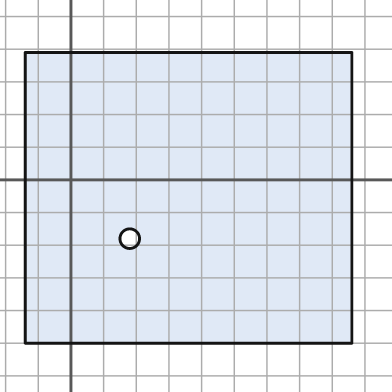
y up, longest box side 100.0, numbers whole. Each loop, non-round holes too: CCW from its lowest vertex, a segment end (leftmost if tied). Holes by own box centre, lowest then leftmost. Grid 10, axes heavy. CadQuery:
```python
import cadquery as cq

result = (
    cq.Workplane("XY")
    .moveTo(-14.0, -50.0)
    .lineTo(86.0, -50.0)
    .lineTo(86.0, 39.0)
    .lineTo(-14.0, 39.0)
    .close()
    .moveTo(18.0, -18.0)
    .circle(3.0)
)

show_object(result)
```